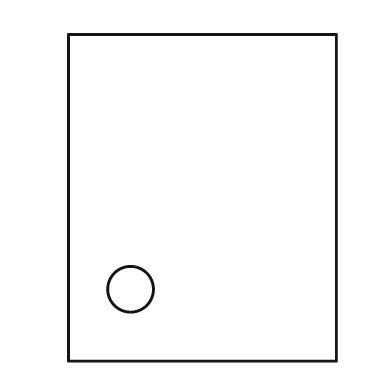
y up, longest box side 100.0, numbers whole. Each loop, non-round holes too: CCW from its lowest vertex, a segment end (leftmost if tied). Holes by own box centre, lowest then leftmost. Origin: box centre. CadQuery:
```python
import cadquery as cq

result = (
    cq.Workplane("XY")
    .moveTo(-41.0, -50.0)
    .lineTo(41.0, -50.0)
    .lineTo(41.0, 50.0)
    .lineTo(-41.0, 50.0)
    .close()
    .moveTo(-22.0, -28.0)
    .circle(7.0)
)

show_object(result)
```